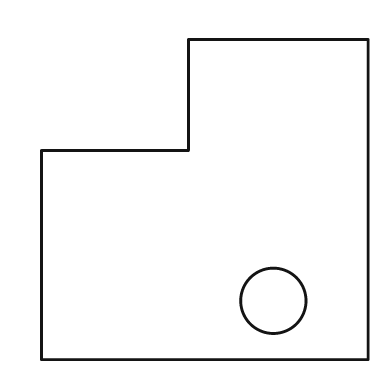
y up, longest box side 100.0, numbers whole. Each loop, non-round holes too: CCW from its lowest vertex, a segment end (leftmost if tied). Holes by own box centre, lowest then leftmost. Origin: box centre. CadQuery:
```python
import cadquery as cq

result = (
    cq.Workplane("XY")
    .moveTo(-50.0, -49.0)
    .lineTo(50.0, -49.0)
    .lineTo(50.0, 49.0)
    .lineTo(-5.0, 49.0)
    .lineTo(-5.0, 15.0)
    .lineTo(-50.0, 15.0)
    .close()
    .moveTo(21.0, -31.0)
    .circle(10.0)
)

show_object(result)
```